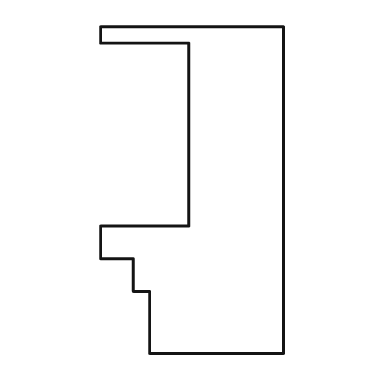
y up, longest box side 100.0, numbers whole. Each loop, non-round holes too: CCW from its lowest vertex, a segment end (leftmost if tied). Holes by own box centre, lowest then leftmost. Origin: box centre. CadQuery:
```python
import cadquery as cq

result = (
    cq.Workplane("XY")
    .moveTo(-13.0, -50.0)
    .lineTo(28.0, -50.0)
    .lineTo(28.0, 50.0)
    .lineTo(-28.0, 50.0)
    .lineTo(-28.0, 45.0)
    .lineTo(-1.0, 45.0)
    .lineTo(-1.0, -11.0)
    .lineTo(-28.0, -11.0)
    .lineTo(-28.0, -21.0)
    .lineTo(-18.0, -21.0)
    .lineTo(-18.0, -31.0)
    .lineTo(-13.0, -31.0)
    .close()
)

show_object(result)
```